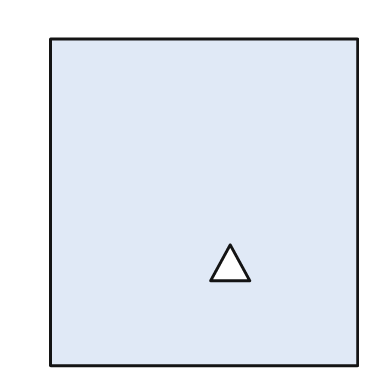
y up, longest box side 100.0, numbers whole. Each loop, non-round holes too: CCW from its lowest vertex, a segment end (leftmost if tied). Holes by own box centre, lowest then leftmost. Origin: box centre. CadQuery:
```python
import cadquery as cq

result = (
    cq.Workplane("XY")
    .moveTo(-47.0, -50.0)
    .lineTo(47.0, -50.0)
    .lineTo(47.0, 50.0)
    .lineTo(-47.0, 50.0)
    .close()
    .moveTo(2.0, -24.0)
    .lineTo(14.0, -24.0)
    .lineTo(8.0, -13.0)
    .close()
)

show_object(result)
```